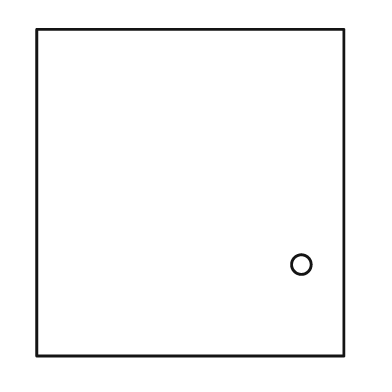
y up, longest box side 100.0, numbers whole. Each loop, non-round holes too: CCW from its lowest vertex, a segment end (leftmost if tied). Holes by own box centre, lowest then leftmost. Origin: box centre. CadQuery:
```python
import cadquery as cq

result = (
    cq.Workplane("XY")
    .moveTo(-47.0, -50.0)
    .lineTo(47.0, -50.0)
    .lineTo(47.0, 50.0)
    .lineTo(-47.0, 50.0)
    .close()
    .moveTo(34.0, -22.0)
    .circle(3.0)
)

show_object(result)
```